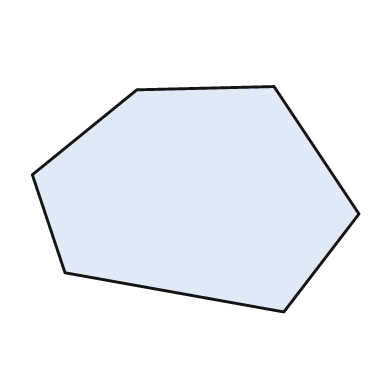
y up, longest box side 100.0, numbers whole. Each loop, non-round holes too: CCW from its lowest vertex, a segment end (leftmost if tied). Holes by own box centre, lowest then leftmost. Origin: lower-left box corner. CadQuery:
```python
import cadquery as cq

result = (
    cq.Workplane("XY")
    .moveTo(77.0, 0.0)
    .lineTo(100.0, 30.0)
    .lineTo(74.0, 69.0)
    .lineTo(32.0, 68.0)
    .lineTo(0.0, 42.0)
    .lineTo(10.0, 12.0)
    .close()
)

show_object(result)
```